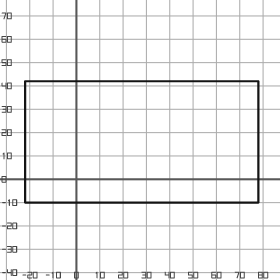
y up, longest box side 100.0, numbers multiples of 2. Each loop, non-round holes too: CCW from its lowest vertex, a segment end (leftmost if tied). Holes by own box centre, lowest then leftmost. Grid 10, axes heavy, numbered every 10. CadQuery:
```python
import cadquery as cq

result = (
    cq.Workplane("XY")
    .moveTo(-22.0, -10.0)
    .lineTo(78.0, -10.0)
    .lineTo(78.0, 42.0)
    .lineTo(-22.0, 42.0)
    .close()
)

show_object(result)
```